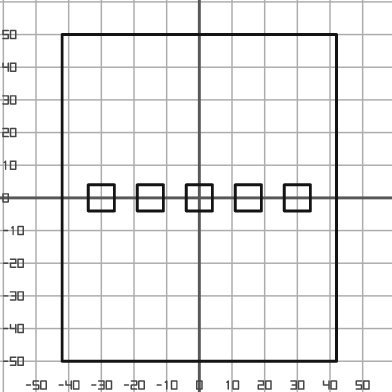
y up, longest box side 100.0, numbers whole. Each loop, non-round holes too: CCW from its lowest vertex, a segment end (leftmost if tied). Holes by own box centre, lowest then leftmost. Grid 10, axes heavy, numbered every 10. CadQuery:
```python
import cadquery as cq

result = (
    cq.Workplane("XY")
    .moveTo(-42.0, -50.0)
    .lineTo(42.0, -50.0)
    .lineTo(42.0, 50.0)
    .lineTo(-42.0, 50.0)
    .close()
    .moveTo(-34.0, -4.0)
    .lineTo(-26.0, -4.0)
    .lineTo(-26.0, 4.0)
    .lineTo(-34.0, 4.0)
    .close()
    .moveTo(-19.0, -4.0)
    .lineTo(-11.0, -4.0)
    .lineTo(-11.0, 4.0)
    .lineTo(-19.0, 4.0)
    .close()
    .moveTo(-4.0, -4.0)
    .lineTo(4.0, -4.0)
    .lineTo(4.0, 4.0)
    .lineTo(-4.0, 4.0)
    .close()
    .moveTo(11.0, -4.0)
    .lineTo(19.0, -4.0)
    .lineTo(19.0, 4.0)
    .lineTo(11.0, 4.0)
    .close()
    .moveTo(26.0, -4.0)
    .lineTo(34.0, -4.0)
    .lineTo(34.0, 4.0)
    .lineTo(26.0, 4.0)
    .close()
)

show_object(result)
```